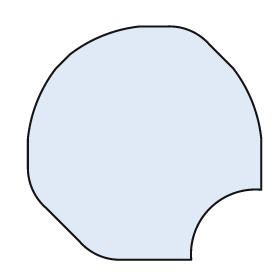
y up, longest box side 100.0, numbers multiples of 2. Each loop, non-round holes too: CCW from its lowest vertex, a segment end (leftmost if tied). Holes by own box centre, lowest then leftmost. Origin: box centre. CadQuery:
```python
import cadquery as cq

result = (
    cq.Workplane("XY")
    .moveTo(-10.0, -50.0)
    .lineTo(20.0, -50.0)
    .threePointArc((28.0, -28.0), (50.0, -20.0))
    .lineTo(50.0, 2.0)
    .threePointArc((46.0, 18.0), (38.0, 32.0))
    .lineTo(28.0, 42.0)
    .threePointArc((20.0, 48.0), (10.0, 50.0))
    .lineTo(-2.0, 50.0)
    .threePointArc((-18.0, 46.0), (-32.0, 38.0))
    .lineTo(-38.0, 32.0)
    .threePointArc((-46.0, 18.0), (-50.0, 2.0))
    .lineTo(-50.0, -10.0)
    .threePointArc((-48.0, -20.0), (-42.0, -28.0))
    .lineTo(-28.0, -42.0)
    .threePointArc((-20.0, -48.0), (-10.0, -50.0))
    .close()
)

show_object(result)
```